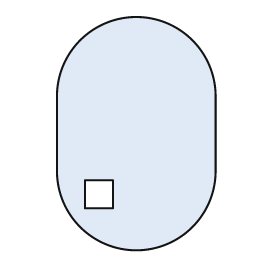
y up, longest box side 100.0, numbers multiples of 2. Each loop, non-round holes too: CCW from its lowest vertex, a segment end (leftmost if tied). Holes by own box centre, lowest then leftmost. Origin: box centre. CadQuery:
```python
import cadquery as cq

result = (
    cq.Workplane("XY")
    .moveTo(-34.0, -16.0)
    .threePointArc((0.0, -50.0), (34.0, -16.0))
    .lineTo(34.0, 16.0)
    .threePointArc((0.0, 50.0), (-34.0, 16.0))
    .close()
    .moveTo(-22.0, -32.0)
    .lineTo(-10.0, -32.0)
    .lineTo(-10.0, -20.0)
    .lineTo(-22.0, -20.0)
    .close()
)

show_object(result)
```